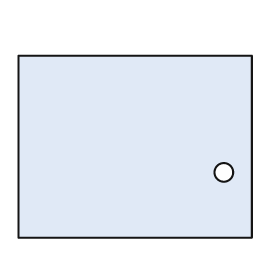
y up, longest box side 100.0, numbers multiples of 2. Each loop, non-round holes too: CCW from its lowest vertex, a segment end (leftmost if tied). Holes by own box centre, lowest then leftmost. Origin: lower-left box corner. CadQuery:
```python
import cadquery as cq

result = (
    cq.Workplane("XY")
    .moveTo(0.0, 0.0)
    .lineTo(100.0, 0.0)
    .lineTo(100.0, 78.0)
    .lineTo(0.0, 78.0)
    .close()
    .moveTo(88.0, 28.0)
    .circle(4.0)
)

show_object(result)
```